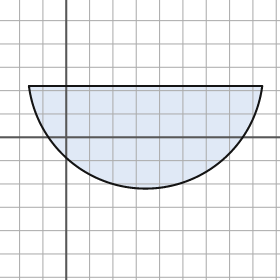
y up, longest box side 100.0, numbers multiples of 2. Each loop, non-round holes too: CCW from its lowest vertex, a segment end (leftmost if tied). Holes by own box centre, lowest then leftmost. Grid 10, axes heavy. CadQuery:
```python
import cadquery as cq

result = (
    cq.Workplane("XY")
    .moveTo(-16.0, 22.0)
    .threePointArc((34.0, -22.0), (84.0, 22.0))
    .close()
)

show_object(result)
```